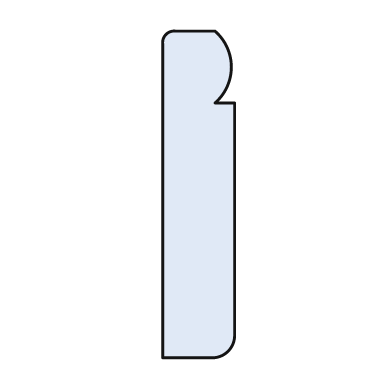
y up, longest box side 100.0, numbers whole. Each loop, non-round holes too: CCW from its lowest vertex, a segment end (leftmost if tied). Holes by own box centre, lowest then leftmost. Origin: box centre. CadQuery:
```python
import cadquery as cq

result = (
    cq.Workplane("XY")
    .moveTo(-11.0, -50.0)
    .lineTo(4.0, -50.0)
    .threePointArc((9.0, -48.0), (11.0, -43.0))
    .lineTo(11.0, 28.0)
    .lineTo(5.0, 28.0)
    .threePointArc((10.0, 39.0), (5.0, 50.0))
    .lineTo(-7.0, 50.0)
    .threePointArc((-10.0, 49.0), (-11.0, 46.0))
    .close()
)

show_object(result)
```